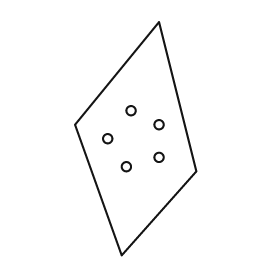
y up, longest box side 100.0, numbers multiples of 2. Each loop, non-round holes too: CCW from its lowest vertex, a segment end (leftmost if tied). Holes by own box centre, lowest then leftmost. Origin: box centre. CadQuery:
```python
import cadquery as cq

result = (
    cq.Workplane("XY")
    .moveTo(-6.0, -50.0)
    .lineTo(26.0, -14.0)
    .lineTo(10.0, 50.0)
    .lineTo(-26.0, 6.0)
    .close()
    .moveTo(-4.0, -12.0)
    .circle(2.0)
    .moveTo(10.0, -8.0)
    .circle(2.0)
    .moveTo(-12.0, 0.0)
    .circle(2.0)
    .moveTo(10.0, 6.0)
    .circle(2.0)
    .moveTo(-2.0, 12.0)
    .circle(2.0)
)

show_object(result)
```